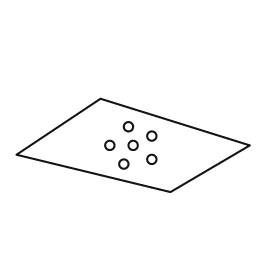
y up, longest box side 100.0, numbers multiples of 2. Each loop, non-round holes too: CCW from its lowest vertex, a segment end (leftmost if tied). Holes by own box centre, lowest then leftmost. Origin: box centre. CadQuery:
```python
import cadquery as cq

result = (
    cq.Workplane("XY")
    .moveTo(16.0, -20.0)
    .lineTo(50.0, 0.0)
    .lineTo(-14.0, 20.0)
    .lineTo(-50.0, -4.0)
    .close()
    .moveTo(-4.0, -8.0)
    .circle(2.0)
    .moveTo(8.0, -6.0)
    .circle(2.0)
    .moveTo(-10.0, 0.0)
    .circle(2.0)
    .moveTo(0.0, 0.0)
    .circle(2.0)
    .moveTo(8.0, 4.0)
    .circle(2.0)
    .moveTo(-2.0, 8.0)
    .circle(2.0)
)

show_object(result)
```